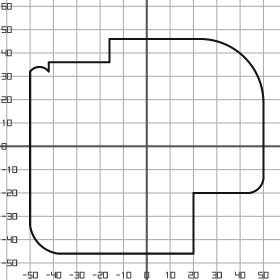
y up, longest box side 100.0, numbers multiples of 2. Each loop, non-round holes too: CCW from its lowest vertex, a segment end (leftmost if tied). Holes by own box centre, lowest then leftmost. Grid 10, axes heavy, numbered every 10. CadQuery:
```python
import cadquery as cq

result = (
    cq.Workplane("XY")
    .moveTo(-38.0, -46.0)
    .lineTo(20.0, -46.0)
    .lineTo(20.0, -20.0)
    .lineTo(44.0, -20.0)
    .threePointArc((48.0, -18.0), (50.0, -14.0))
    .lineTo(50.0, 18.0)
    .threePointArc((42.0, 38.0), (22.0, 46.0))
    .lineTo(-16.0, 46.0)
    .lineTo(-16.0, 36.0)
    .lineTo(-42.0, 36.0)
    .lineTo(-42.0, 32.0)
    .threePointArc((-46.0, 34.0), (-50.0, 32.0))
    .lineTo(-50.0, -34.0)
    .threePointArc((-46.0, -42.0), (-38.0, -46.0))
    .close()
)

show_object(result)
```